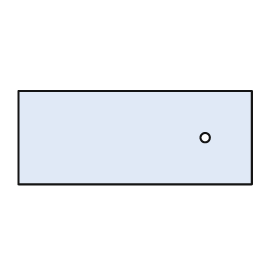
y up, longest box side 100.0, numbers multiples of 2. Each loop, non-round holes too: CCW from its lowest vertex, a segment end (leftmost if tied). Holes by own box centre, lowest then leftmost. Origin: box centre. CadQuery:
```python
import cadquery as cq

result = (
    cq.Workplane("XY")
    .moveTo(-50.0, -20.0)
    .lineTo(50.0, -20.0)
    .lineTo(50.0, 20.0)
    .lineTo(-50.0, 20.0)
    .close()
    .moveTo(30.0, 0.0)
    .circle(2.0)
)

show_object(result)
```